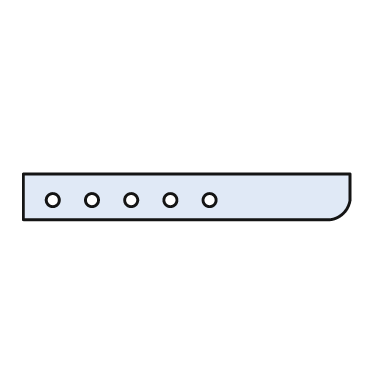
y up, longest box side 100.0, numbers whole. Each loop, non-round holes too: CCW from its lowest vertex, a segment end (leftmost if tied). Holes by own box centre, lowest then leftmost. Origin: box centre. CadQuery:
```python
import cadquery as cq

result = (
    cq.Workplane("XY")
    .moveTo(-50.0, -7.0)
    .lineTo(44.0, -7.0)
    .threePointArc((48.0, -5.0), (50.0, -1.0))
    .lineTo(50.0, 7.0)
    .lineTo(-50.0, 7.0)
    .close()
    .moveTo(-41.0, -1.0)
    .circle(2.0)
    .moveTo(-29.0, -1.0)
    .circle(2.0)
    .moveTo(-17.0, -1.0)
    .circle(2.0)
    .moveTo(-5.0, -1.0)
    .circle(2.0)
    .moveTo(7.0, -1.0)
    .circle(2.0)
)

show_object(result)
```